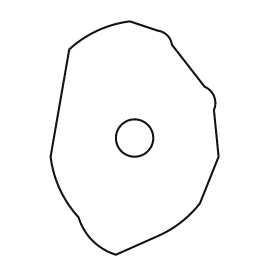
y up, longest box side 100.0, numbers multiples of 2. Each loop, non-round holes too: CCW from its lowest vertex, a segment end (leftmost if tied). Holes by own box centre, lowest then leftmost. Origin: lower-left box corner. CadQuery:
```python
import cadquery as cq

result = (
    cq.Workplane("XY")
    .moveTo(28.0, 0.0)
    .lineTo(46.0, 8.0)
    .threePointArc((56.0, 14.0), (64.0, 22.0))
    .lineTo(72.0, 42.0)
    .lineTo(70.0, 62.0)
    .threePointArc((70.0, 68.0), (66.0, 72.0))
    .lineTo(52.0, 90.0)
    .threePointArc((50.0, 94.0), (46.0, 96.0))
    .lineTo(34.0, 100.0)
    .threePointArc((20.0, 96.0), (8.0, 88.0))
    .lineTo(0.0, 42.0)
    .threePointArc((4.0, 28.0), (12.0, 16.0))
    .threePointArc((18.0, 6.0), (28.0, 0.0))
    .close()
    .moveTo(36.0, 50.0)
    .circle(8.0)
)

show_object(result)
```